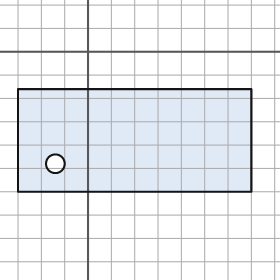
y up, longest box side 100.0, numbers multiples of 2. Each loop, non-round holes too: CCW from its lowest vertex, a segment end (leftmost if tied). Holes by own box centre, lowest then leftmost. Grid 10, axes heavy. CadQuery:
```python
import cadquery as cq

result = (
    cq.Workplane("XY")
    .moveTo(-30.0, -60.0)
    .lineTo(70.0, -60.0)
    .lineTo(70.0, -16.0)
    .lineTo(-30.0, -16.0)
    .close()
    .moveTo(-14.0, -48.0)
    .circle(4.0)
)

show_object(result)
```